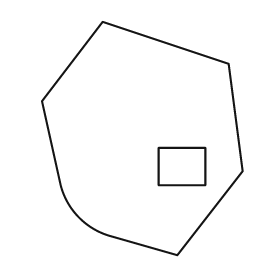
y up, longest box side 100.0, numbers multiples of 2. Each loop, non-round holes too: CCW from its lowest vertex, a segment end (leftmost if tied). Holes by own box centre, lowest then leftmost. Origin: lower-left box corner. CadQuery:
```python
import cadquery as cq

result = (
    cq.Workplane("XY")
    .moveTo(58.0, 0.0)
    .lineTo(86.0, 36.0)
    .lineTo(80.0, 82.0)
    .lineTo(26.0, 100.0)
    .lineTo(0.0, 66.0)
    .lineTo(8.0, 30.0)
    .threePointArc((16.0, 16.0), (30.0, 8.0))
    .close()
    .moveTo(50.0, 30.0)
    .lineTo(70.0, 30.0)
    .lineTo(70.0, 46.0)
    .lineTo(50.0, 46.0)
    .close()
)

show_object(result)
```